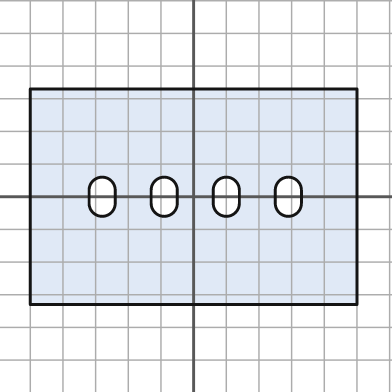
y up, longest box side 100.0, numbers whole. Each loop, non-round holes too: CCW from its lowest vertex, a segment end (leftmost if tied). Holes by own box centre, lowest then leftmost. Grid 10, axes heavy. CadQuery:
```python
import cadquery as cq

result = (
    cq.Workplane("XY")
    .moveTo(-50.0, -33.0)
    .lineTo(50.0, -33.0)
    .lineTo(50.0, 33.0)
    .lineTo(-50.0, 33.0)
    .close()
    .moveTo(-32.0, -2.0)
    .threePointArc((-28.0, -6.0), (-24.0, -2.0))
    .lineTo(-24.0, 2.0)
    .threePointArc((-28.0, 6.0), (-32.0, 2.0))
    .close()
    .moveTo(-13.0, -2.0)
    .threePointArc((-9.0, -6.0), (-5.0, -2.0))
    .lineTo(-5.0, 2.0)
    .threePointArc((-9.0, 6.0), (-13.0, 2.0))
    .close()
    .moveTo(6.0, -2.0)
    .threePointArc((10.0, -6.0), (14.0, -2.0))
    .lineTo(14.0, 2.0)
    .threePointArc((10.0, 6.0), (6.0, 2.0))
    .close()
    .moveTo(25.0, -2.0)
    .threePointArc((29.0, -6.0), (33.0, -2.0))
    .lineTo(33.0, 2.0)
    .threePointArc((29.0, 6.0), (25.0, 2.0))
    .close()
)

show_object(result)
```